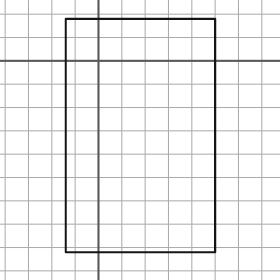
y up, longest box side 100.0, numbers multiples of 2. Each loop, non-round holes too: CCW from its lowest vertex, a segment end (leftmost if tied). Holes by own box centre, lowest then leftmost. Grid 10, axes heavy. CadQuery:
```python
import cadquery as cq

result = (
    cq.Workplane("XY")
    .moveTo(-14.0, -82.0)
    .lineTo(50.0, -82.0)
    .lineTo(50.0, 18.0)
    .lineTo(-14.0, 18.0)
    .close()
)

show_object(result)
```